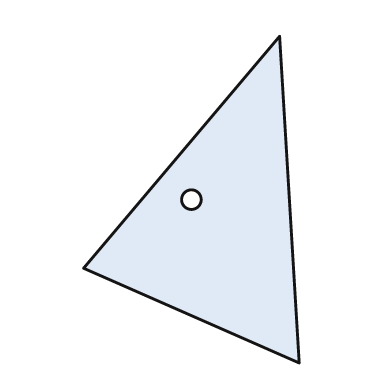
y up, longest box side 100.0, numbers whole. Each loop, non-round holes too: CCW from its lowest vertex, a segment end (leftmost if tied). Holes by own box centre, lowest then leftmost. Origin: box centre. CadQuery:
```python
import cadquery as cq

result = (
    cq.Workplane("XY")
    .moveTo(33.0, -50.0)
    .lineTo(27.0, 50.0)
    .lineTo(-33.0, -21.0)
    .close()
    .moveTo(0.0, 0.0)
    .circle(3.0)
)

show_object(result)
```